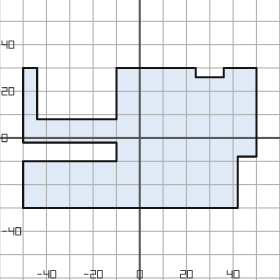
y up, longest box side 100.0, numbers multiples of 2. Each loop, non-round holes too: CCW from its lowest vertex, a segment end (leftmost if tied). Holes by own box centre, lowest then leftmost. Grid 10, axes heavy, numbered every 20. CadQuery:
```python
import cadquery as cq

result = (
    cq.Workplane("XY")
    .moveTo(-50.0, -30.0)
    .lineTo(42.0, -30.0)
    .lineTo(42.0, -8.0)
    .lineTo(50.0, -8.0)
    .lineTo(50.0, 30.0)
    .lineTo(36.0, 30.0)
    .lineTo(36.0, 26.0)
    .lineTo(24.0, 26.0)
    .lineTo(24.0, 30.0)
    .lineTo(-10.0, 30.0)
    .lineTo(-10.0, 8.0)
    .lineTo(-44.0, 8.0)
    .lineTo(-44.0, 30.0)
    .lineTo(-50.0, 30.0)
    .lineTo(-50.0, -2.0)
    .lineTo(-10.0, -2.0)
    .lineTo(-10.0, -10.0)
    .lineTo(-50.0, -10.0)
    .close()
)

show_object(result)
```